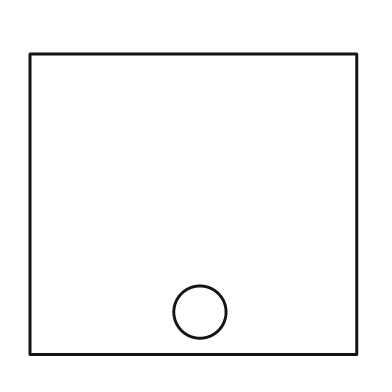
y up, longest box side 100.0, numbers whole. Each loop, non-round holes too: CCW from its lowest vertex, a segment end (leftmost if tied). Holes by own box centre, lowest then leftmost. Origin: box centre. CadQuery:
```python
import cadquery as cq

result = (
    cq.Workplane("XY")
    .moveTo(-50.0, -46.0)
    .lineTo(50.0, -46.0)
    .lineTo(50.0, 46.0)
    .lineTo(-50.0, 46.0)
    .close()
    .moveTo(2.0, -33.0)
    .circle(8.0)
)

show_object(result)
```